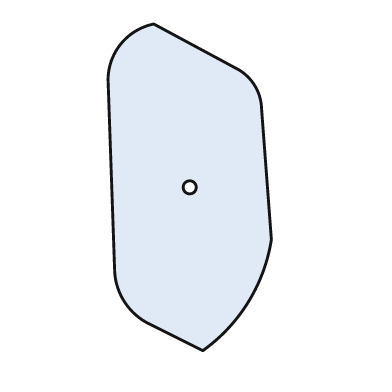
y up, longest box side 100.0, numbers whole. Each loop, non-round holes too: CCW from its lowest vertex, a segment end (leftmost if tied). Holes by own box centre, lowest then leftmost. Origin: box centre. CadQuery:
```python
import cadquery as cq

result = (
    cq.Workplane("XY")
    .moveTo(4.0, -50.0)
    .threePointArc((18.0, -35.0), (25.0, -16.0))
    .lineTo(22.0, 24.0)
    .threePointArc((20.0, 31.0), (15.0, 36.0))
    .lineTo(-11.0, 50.0)
    .threePointArc((-21.0, 44.0), (-25.0, 33.0))
    .lineTo(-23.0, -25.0)
    .threePointArc((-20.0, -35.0), (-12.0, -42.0))
    .close()
    .moveTo(0.0, 0.0)
    .circle(2.0)
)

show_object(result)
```